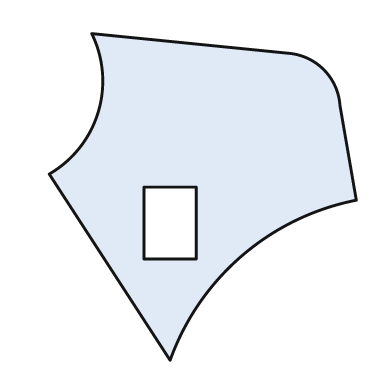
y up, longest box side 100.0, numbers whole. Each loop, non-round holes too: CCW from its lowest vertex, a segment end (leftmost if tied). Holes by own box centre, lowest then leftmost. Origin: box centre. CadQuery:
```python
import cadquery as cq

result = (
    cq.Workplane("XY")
    .moveTo(-10.0, -50.0)
    .threePointArc((12.0, -18.0), (47.0, -1.0))
    .lineTo(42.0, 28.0)
    .threePointArc((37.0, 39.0), (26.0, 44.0))
    .lineTo(-34.0, 50.0)
    .threePointArc((-32.0, 26.0), (-47.0, 7.0))
    .close()
    .moveTo(-18.0, -19.0)
    .lineTo(-2.0, -19.0)
    .lineTo(-2.0, 3.0)
    .lineTo(-18.0, 3.0)
    .close()
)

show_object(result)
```